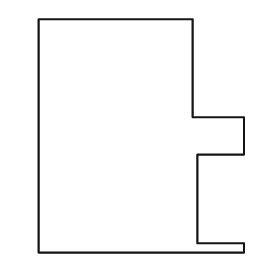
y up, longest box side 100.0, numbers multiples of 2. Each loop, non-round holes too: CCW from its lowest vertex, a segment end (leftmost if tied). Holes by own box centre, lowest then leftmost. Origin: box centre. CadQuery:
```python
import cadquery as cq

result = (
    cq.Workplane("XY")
    .moveTo(-44.0, -50.0)
    .lineTo(44.0, -50.0)
    .lineTo(44.0, -46.0)
    .lineTo(24.0, -46.0)
    .lineTo(24.0, -8.0)
    .lineTo(44.0, -8.0)
    .lineTo(44.0, 8.0)
    .lineTo(22.0, 8.0)
    .lineTo(22.0, 50.0)
    .lineTo(-44.0, 50.0)
    .close()
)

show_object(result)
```